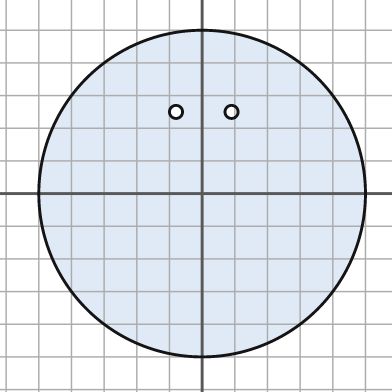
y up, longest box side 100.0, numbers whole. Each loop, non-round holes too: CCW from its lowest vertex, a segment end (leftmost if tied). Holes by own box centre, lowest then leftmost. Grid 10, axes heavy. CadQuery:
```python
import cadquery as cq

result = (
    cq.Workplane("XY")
    .moveTo(0.0, 0.0)
    .circle(50.0)
    .moveTo(-8.0, 25.0)
    .circle(2.0)
    .moveTo(9.0, 25.0)
    .circle(2.0)
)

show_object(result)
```